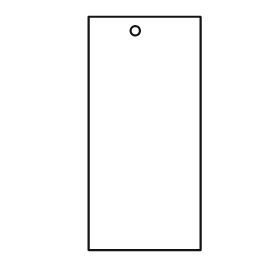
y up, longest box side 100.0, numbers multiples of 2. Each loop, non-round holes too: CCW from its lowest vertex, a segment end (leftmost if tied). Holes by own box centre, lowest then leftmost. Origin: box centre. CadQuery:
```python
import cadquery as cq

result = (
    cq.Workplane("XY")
    .moveTo(-24.0, -50.0)
    .lineTo(24.0, -50.0)
    .lineTo(24.0, 50.0)
    .lineTo(-24.0, 50.0)
    .close()
    .moveTo(-4.0, 44.0)
    .circle(2.0)
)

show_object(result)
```